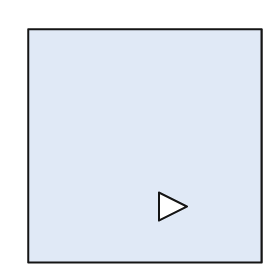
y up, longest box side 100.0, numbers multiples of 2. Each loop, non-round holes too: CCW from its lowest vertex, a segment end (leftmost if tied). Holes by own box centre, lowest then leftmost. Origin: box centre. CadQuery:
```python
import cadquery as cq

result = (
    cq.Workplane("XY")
    .moveTo(-50.0, -50.0)
    .lineTo(50.0, -50.0)
    .lineTo(50.0, 50.0)
    .lineTo(-50.0, 50.0)
    .close()
    .moveTo(6.0, -32.0)
    .lineTo(18.0, -26.0)
    .lineTo(6.0, -20.0)
    .close()
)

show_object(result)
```